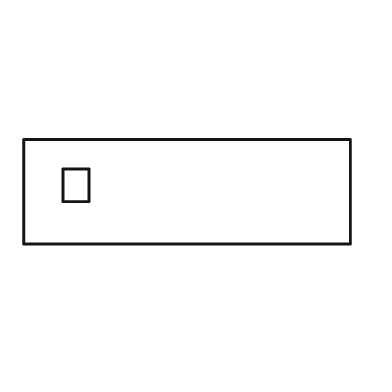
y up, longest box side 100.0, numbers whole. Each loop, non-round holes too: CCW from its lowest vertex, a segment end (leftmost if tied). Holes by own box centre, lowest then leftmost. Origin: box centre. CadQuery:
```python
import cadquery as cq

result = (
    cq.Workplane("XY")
    .moveTo(-50.0, -16.0)
    .lineTo(50.0, -16.0)
    .lineTo(50.0, 16.0)
    .lineTo(-50.0, 16.0)
    .close()
    .moveTo(-38.0, -3.0)
    .lineTo(-30.0, -3.0)
    .lineTo(-30.0, 7.0)
    .lineTo(-38.0, 7.0)
    .close()
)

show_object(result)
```